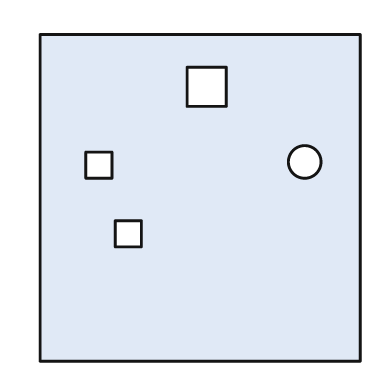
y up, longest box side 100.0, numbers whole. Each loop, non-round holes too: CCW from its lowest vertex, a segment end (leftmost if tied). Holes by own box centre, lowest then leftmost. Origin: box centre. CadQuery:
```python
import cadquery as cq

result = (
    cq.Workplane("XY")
    .moveTo(-49.0, -50.0)
    .lineTo(49.0, -50.0)
    .lineTo(49.0, 50.0)
    .lineTo(-49.0, 50.0)
    .close()
    .moveTo(-26.0, -15.0)
    .lineTo(-18.0, -15.0)
    .lineTo(-18.0, -7.0)
    .lineTo(-26.0, -7.0)
    .close()
    .moveTo(-35.0, 6.0)
    .lineTo(-27.0, 6.0)
    .lineTo(-27.0, 14.0)
    .lineTo(-35.0, 14.0)
    .close()
    .moveTo(32.0, 11.0)
    .circle(5.0)
    .moveTo(-4.0, 28.0)
    .lineTo(8.0, 28.0)
    .lineTo(8.0, 40.0)
    .lineTo(-4.0, 40.0)
    .close()
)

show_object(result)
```